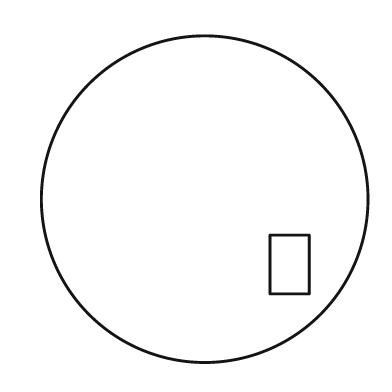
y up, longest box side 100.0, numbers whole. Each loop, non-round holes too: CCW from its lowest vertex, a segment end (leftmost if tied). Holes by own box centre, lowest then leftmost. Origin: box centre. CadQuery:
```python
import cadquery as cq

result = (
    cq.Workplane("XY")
    .moveTo(0.0, 0.0)
    .circle(50.0)
    .moveTo(20.0, -29.0)
    .lineTo(32.0, -29.0)
    .lineTo(32.0, -11.0)
    .lineTo(20.0, -11.0)
    .close()
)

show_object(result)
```